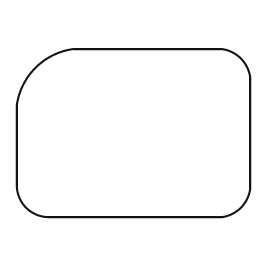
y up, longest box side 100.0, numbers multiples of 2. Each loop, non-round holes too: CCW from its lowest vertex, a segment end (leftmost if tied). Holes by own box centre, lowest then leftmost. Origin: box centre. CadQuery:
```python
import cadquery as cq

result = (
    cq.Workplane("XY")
    .moveTo(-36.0, -36.0)
    .lineTo(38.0, -36.0)
    .threePointArc((46.0, -32.0), (50.0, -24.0))
    .lineTo(50.0, 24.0)
    .threePointArc((46.0, 32.0), (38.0, 36.0))
    .lineTo(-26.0, 36.0)
    .threePointArc((-42.0, 28.0), (-50.0, 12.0))
    .lineTo(-50.0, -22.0)
    .threePointArc((-46.0, -32.0), (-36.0, -36.0))
    .close()
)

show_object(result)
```